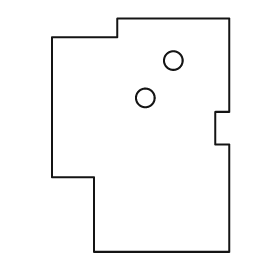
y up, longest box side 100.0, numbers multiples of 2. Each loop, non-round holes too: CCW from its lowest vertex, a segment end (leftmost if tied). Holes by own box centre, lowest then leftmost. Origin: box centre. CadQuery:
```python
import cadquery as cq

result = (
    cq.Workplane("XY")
    .moveTo(-20.0, -50.0)
    .lineTo(38.0, -50.0)
    .lineTo(38.0, -4.0)
    .lineTo(32.0, -4.0)
    .lineTo(32.0, 10.0)
    .lineTo(38.0, 10.0)
    .lineTo(38.0, 50.0)
    .lineTo(-10.0, 50.0)
    .lineTo(-10.0, 42.0)
    .lineTo(-38.0, 42.0)
    .lineTo(-38.0, -18.0)
    .lineTo(-20.0, -18.0)
    .close()
    .moveTo(2.0, 16.0)
    .circle(4.0)
    .moveTo(14.0, 32.0)
    .circle(4.0)
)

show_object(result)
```